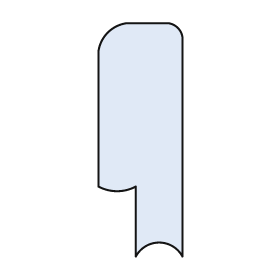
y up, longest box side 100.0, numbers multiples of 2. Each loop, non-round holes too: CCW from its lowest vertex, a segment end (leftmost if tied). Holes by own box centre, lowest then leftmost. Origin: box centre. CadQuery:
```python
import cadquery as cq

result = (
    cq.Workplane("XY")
    .moveTo(-2.0, -50.0)
    .threePointArc((8.0, -44.0), (18.0, -50.0))
    .lineTo(18.0, 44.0)
    .threePointArc((16.0, 48.0), (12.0, 50.0))
    .lineTo(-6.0, 50.0)
    .threePointArc((-14.0, 46.0), (-18.0, 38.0))
    .lineTo(-18.0, -20.0)
    .threePointArc((-10.0, -22.0), (-2.0, -20.0))
    .close()
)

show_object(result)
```